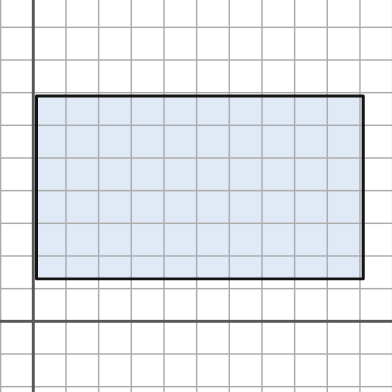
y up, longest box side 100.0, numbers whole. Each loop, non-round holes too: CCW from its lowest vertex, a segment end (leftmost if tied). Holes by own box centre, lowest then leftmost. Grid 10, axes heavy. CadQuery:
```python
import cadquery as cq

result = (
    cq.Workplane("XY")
    .moveTo(1.0, 13.0)
    .lineTo(101.0, 13.0)
    .lineTo(101.0, 69.0)
    .lineTo(1.0, 69.0)
    .close()
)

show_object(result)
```